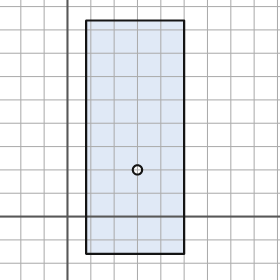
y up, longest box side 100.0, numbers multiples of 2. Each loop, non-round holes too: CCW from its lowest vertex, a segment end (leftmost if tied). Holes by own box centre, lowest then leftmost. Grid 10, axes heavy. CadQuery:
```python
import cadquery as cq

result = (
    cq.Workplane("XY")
    .moveTo(8.0, -16.0)
    .lineTo(50.0, -16.0)
    .lineTo(50.0, 84.0)
    .lineTo(8.0, 84.0)
    .close()
    .moveTo(30.0, 20.0)
    .circle(2.0)
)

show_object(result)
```